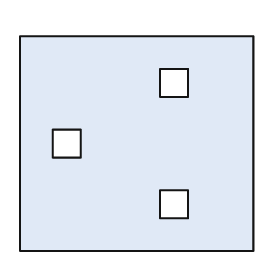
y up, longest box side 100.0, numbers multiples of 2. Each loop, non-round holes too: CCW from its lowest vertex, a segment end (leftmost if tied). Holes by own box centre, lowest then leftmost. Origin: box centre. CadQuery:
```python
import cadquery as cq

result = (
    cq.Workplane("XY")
    .moveTo(-50.0, -46.0)
    .lineTo(50.0, -46.0)
    .lineTo(50.0, 46.0)
    .lineTo(-50.0, 46.0)
    .close()
    .moveTo(10.0, -32.0)
    .lineTo(22.0, -32.0)
    .lineTo(22.0, -20.0)
    .lineTo(10.0, -20.0)
    .close()
    .moveTo(-36.0, -6.0)
    .lineTo(-24.0, -6.0)
    .lineTo(-24.0, 6.0)
    .lineTo(-36.0, 6.0)
    .close()
    .moveTo(10.0, 20.0)
    .lineTo(22.0, 20.0)
    .lineTo(22.0, 32.0)
    .lineTo(10.0, 32.0)
    .close()
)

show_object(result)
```